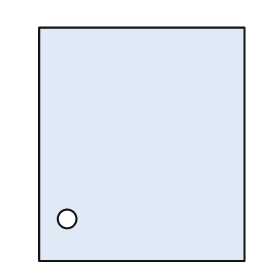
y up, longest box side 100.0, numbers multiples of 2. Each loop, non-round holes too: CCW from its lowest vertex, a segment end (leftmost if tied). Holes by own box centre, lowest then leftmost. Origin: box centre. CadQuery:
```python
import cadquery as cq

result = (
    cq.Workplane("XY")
    .moveTo(-44.0, -50.0)
    .lineTo(44.0, -50.0)
    .lineTo(44.0, 50.0)
    .lineTo(-44.0, 50.0)
    .close()
    .moveTo(-32.0, -32.0)
    .circle(4.0)
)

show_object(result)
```